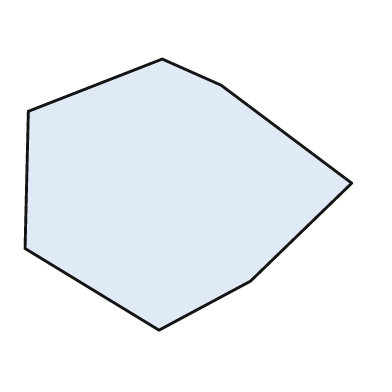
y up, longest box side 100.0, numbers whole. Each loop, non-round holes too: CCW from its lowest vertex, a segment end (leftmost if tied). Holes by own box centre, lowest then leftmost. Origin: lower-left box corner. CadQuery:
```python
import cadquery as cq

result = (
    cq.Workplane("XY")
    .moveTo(41.0, 0.0)
    .lineTo(69.0, 15.0)
    .lineTo(100.0, 45.0)
    .lineTo(60.0, 75.0)
    .lineTo(42.0, 83.0)
    .lineTo(1.0, 67.0)
    .lineTo(0.0, 25.0)
    .close()
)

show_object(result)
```